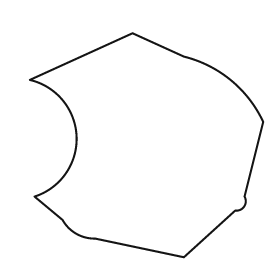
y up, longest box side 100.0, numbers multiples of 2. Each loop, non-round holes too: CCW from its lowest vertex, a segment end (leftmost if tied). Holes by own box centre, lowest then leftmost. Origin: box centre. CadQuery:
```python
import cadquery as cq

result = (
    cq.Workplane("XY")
    .moveTo(16.0, -48.0)
    .lineTo(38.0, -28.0)
    .threePointArc((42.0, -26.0), (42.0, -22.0))
    .lineTo(50.0, 10.0)
    .threePointArc((36.0, 28.0), (16.0, 38.0))
    .lineTo(-6.0, 48.0)
    .lineTo(-50.0, 28.0)
    .threePointArc((-30.0, 4.0), (-48.0, -22.0))
    .lineTo(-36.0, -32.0)
    .threePointArc((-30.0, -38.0), (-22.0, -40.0))
    .close()
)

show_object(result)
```